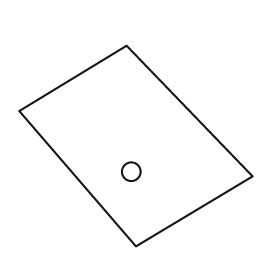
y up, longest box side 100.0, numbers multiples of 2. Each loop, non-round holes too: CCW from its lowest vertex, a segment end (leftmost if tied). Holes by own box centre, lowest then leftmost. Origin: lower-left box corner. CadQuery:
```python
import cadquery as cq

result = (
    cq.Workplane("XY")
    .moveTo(50.0, 0.0)
    .lineTo(100.0, 30.0)
    .lineTo(46.0, 86.0)
    .lineTo(0.0, 58.0)
    .close()
    .moveTo(48.0, 32.0)
    .circle(4.0)
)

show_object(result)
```